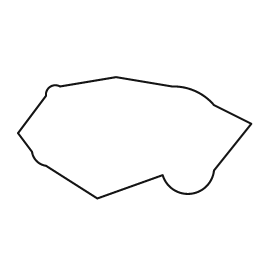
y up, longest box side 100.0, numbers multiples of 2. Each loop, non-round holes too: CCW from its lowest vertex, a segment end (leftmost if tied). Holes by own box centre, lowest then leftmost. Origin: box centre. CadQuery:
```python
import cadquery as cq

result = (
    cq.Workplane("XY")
    .moveTo(-16.0, -26.0)
    .lineTo(12.0, -16.0)
    .threePointArc((24.0, -24.0), (34.0, -14.0))
    .lineTo(50.0, 6.0)
    .lineTo(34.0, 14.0)
    .threePointArc((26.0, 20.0), (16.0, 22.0))
    .lineTo(-8.0, 26.0)
    .lineTo(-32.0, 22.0)
    .threePointArc((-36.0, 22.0), (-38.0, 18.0))
    .lineTo(-50.0, 2.0)
    .lineTo(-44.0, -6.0)
    .threePointArc((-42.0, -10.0), (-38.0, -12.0))
    .close()
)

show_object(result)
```